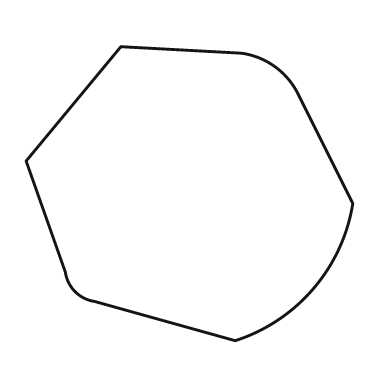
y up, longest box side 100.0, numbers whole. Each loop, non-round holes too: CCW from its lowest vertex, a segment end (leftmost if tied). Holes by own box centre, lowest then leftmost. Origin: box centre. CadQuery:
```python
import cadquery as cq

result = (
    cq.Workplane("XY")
    .moveTo(14.0, -45.0)
    .threePointArc((38.0, -29.0), (50.0, -3.0))
    .lineTo(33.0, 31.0)
    .threePointArc((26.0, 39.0), (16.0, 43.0))
    .lineTo(-21.0, 45.0)
    .lineTo(-50.0, 10.0)
    .lineTo(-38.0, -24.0)
    .threePointArc((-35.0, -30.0), (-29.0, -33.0))
    .close()
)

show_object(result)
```